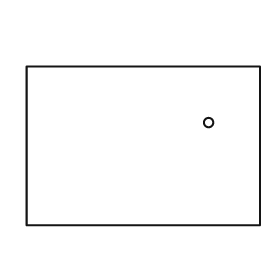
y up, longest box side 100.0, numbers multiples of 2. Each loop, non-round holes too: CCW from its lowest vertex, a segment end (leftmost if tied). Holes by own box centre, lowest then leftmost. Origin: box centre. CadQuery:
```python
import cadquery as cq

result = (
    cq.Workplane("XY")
    .moveTo(-50.0, -34.0)
    .lineTo(50.0, -34.0)
    .lineTo(50.0, 34.0)
    .lineTo(-50.0, 34.0)
    .close()
    .moveTo(28.0, 10.0)
    .circle(2.0)
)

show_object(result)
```